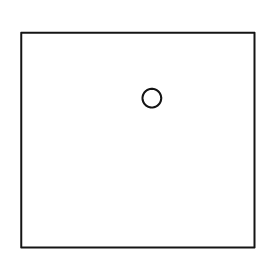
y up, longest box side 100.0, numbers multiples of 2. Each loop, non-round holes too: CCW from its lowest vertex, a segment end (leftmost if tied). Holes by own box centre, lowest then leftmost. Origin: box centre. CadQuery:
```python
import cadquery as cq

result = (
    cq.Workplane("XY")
    .moveTo(-50.0, -46.0)
    .lineTo(50.0, -46.0)
    .lineTo(50.0, 46.0)
    .lineTo(-50.0, 46.0)
    .close()
    .moveTo(6.0, 18.0)
    .circle(4.0)
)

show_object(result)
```